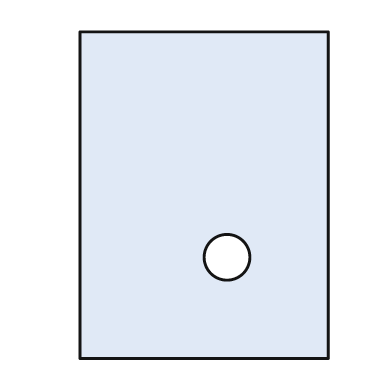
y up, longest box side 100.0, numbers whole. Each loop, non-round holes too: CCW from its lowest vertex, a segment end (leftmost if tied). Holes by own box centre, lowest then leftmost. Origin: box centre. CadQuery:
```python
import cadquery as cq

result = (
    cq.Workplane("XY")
    .moveTo(-38.0, -50.0)
    .lineTo(38.0, -50.0)
    .lineTo(38.0, 50.0)
    .lineTo(-38.0, 50.0)
    .close()
    .moveTo(7.0, -19.0)
    .circle(7.0)
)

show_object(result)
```